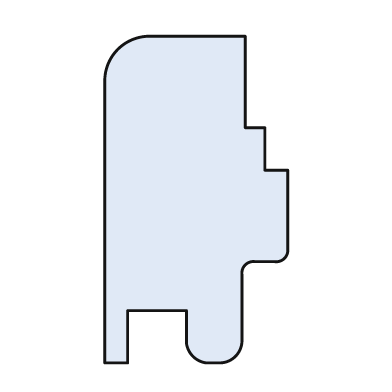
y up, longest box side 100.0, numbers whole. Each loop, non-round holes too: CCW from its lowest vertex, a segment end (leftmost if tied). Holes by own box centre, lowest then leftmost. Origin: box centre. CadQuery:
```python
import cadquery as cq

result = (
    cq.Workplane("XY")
    .moveTo(-28.0, -50.0)
    .lineTo(-21.0, -50.0)
    .lineTo(-21.0, -34.0)
    .lineTo(-3.0, -34.0)
    .lineTo(-3.0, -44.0)
    .threePointArc((-1.0, -48.0), (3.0, -50.0))
    .lineTo(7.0, -50.0)
    .threePointArc((12.0, -48.0), (14.0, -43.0))
    .lineTo(14.0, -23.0)
    .threePointArc((15.0, -20.0), (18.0, -19.0))
    .lineTo(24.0, -19.0)
    .threePointArc((27.0, -18.0), (28.0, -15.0))
    .lineTo(28.0, 9.0)
    .lineTo(21.0, 9.0)
    .lineTo(21.0, 22.0)
    .lineTo(15.0, 22.0)
    .lineTo(15.0, 50.0)
    .lineTo(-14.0, 50.0)
    .threePointArc((-24.0, 46.0), (-28.0, 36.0))
    .close()
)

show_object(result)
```